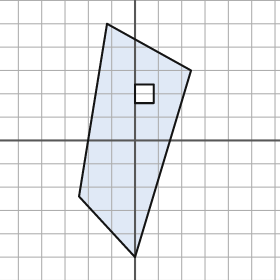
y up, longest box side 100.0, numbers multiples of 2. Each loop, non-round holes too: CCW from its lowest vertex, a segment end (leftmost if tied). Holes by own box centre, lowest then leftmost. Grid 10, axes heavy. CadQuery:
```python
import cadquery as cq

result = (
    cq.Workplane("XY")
    .moveTo(0.0, -50.0)
    .lineTo(24.0, 30.0)
    .lineTo(-12.0, 50.0)
    .lineTo(-24.0, -24.0)
    .close()
    .moveTo(0.0, 16.0)
    .lineTo(8.0, 16.0)
    .lineTo(8.0, 24.0)
    .lineTo(0.0, 24.0)
    .close()
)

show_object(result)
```